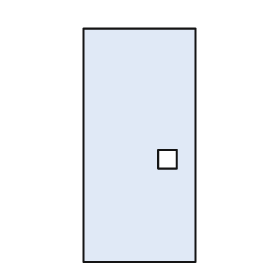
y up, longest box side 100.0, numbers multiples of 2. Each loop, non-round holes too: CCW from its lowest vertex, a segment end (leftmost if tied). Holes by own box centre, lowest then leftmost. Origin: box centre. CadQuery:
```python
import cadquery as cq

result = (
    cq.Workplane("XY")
    .moveTo(-24.0, -50.0)
    .lineTo(24.0, -50.0)
    .lineTo(24.0, 50.0)
    .lineTo(-24.0, 50.0)
    .close()
    .moveTo(8.0, -10.0)
    .lineTo(16.0, -10.0)
    .lineTo(16.0, -2.0)
    .lineTo(8.0, -2.0)
    .close()
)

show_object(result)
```